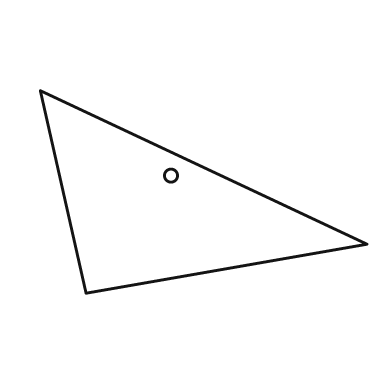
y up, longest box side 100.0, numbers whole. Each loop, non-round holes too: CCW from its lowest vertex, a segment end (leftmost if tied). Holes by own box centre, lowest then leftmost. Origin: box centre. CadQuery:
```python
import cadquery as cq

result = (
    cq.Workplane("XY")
    .moveTo(-36.0, -31.0)
    .lineTo(50.0, -16.0)
    .lineTo(-50.0, 31.0)
    .close()
    .moveTo(-10.0, 5.0)
    .circle(2.0)
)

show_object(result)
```